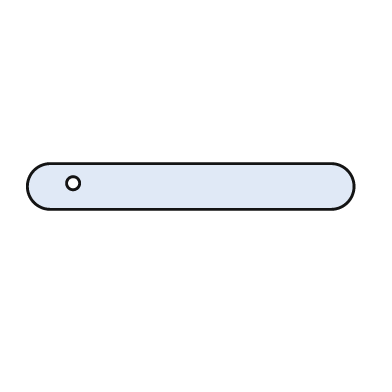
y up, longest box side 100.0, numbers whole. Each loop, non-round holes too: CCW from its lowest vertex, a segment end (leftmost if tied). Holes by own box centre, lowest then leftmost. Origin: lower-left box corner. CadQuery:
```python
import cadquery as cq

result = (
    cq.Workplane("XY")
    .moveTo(7.0, 0.0)
    .lineTo(93.0, 0.0)
    .threePointArc((100.0, 7.0), (93.0, 14.0))
    .lineTo(7.0, 14.0)
    .threePointArc((0.0, 7.0), (7.0, 0.0))
    .close()
    .moveTo(14.0, 8.0)
    .circle(2.0)
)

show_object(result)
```